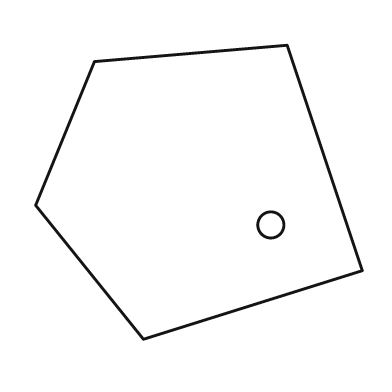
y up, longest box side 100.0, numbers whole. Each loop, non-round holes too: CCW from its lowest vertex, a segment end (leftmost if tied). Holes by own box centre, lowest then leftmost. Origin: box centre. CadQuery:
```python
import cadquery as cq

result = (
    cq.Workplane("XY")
    .moveTo(-17.0, -45.0)
    .lineTo(50.0, -24.0)
    .lineTo(27.0, 45.0)
    .lineTo(-32.0, 40.0)
    .lineTo(-50.0, -4.0)
    .close()
    .moveTo(22.0, -10.0)
    .circle(4.0)
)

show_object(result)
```